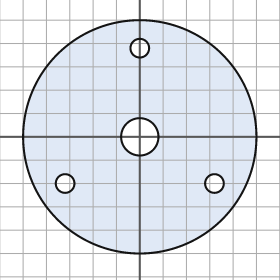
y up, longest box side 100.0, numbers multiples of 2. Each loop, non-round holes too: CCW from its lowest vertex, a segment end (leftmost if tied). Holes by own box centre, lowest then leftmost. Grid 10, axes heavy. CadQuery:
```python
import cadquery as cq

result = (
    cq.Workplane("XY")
    .moveTo(0.0, 0.0)
    .circle(50.0)
    .moveTo(-32.0, -20.0)
    .circle(4.0)
    .moveTo(32.0, -20.0)
    .circle(4.0)
    .moveTo(0.0, 0.0)
    .circle(8.0)
    .moveTo(0.0, 38.0)
    .circle(4.0)
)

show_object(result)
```